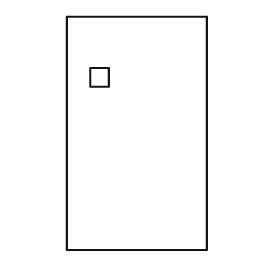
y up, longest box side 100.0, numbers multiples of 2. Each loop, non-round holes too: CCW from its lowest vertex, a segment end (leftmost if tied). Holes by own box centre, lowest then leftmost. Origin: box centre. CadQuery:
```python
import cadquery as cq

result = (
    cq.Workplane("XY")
    .moveTo(-30.0, -50.0)
    .lineTo(30.0, -50.0)
    .lineTo(30.0, 50.0)
    .lineTo(-30.0, 50.0)
    .close()
    .moveTo(-20.0, 20.0)
    .lineTo(-12.0, 20.0)
    .lineTo(-12.0, 28.0)
    .lineTo(-20.0, 28.0)
    .close()
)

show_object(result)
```